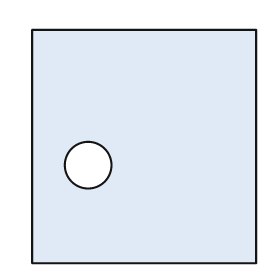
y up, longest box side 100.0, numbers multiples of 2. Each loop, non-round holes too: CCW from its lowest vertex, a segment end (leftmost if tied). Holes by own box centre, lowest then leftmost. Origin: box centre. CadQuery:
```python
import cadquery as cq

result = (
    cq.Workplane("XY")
    .moveTo(-48.0, -50.0)
    .lineTo(48.0, -50.0)
    .lineTo(48.0, 50.0)
    .lineTo(-48.0, 50.0)
    .close()
    .moveTo(-24.0, -8.0)
    .circle(10.0)
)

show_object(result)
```